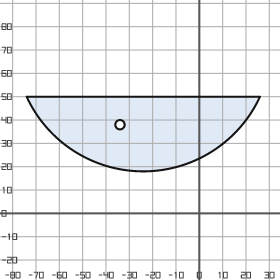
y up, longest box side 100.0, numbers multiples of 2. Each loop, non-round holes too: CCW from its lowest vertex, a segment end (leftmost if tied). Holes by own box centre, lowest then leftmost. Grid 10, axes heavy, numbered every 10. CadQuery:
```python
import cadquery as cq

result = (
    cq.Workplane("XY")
    .moveTo(-74.0, 50.0)
    .threePointArc((-24.0, 18.0), (26.0, 50.0))
    .close()
    .moveTo(-34.0, 38.0)
    .circle(2.0)
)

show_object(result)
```